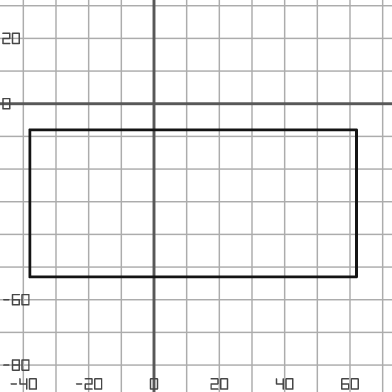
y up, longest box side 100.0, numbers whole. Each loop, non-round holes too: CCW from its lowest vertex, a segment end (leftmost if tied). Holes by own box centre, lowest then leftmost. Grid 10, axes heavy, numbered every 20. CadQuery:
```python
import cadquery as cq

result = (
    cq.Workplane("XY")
    .moveTo(-38.0, -53.0)
    .lineTo(62.0, -53.0)
    .lineTo(62.0, -8.0)
    .lineTo(-38.0, -8.0)
    .close()
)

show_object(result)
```